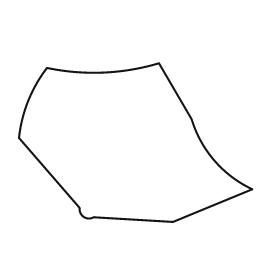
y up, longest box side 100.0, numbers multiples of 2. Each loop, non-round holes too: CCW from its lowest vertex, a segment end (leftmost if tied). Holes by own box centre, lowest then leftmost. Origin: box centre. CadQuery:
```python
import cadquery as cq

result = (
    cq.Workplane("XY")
    .moveTo(16.0, -34.0)
    .lineTo(50.0, -20.0)
    .threePointArc((34.0, -8.0), (24.0, 10.0))
    .lineTo(10.0, 34.0)
    .threePointArc((-14.0, 30.0), (-38.0, 32.0))
    .threePointArc((-46.0, 18.0), (-50.0, 2.0))
    .lineTo(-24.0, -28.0)
    .threePointArc((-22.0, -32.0), (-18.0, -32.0))
    .close()
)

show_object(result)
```